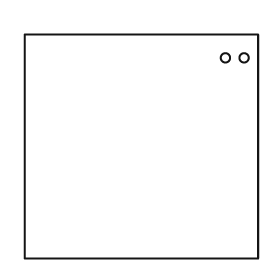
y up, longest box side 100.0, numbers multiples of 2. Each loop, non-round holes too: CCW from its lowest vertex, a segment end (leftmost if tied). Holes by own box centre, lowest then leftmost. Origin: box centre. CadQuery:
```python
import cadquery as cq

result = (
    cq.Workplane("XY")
    .moveTo(-50.0, -48.0)
    .lineTo(50.0, -48.0)
    .lineTo(50.0, 48.0)
    .lineTo(-50.0, 48.0)
    .close()
    .moveTo(36.0, 38.0)
    .circle(2.0)
    .moveTo(44.0, 38.0)
    .circle(2.0)
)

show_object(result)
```